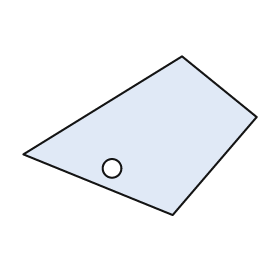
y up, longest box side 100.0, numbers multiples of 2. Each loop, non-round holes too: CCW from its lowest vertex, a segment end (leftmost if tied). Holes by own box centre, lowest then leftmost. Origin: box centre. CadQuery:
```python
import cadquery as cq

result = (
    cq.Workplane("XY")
    .moveTo(14.0, -34.0)
    .lineTo(50.0, 8.0)
    .lineTo(18.0, 34.0)
    .lineTo(-50.0, -8.0)
    .close()
    .moveTo(-12.0, -14.0)
    .circle(4.0)
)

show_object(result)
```